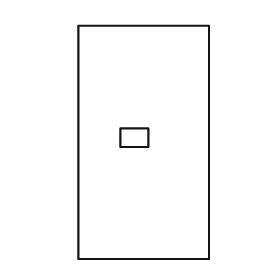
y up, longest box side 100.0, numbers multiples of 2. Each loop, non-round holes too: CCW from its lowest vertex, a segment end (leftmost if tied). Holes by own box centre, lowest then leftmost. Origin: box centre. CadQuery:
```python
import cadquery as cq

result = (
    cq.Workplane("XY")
    .moveTo(-28.0, -50.0)
    .lineTo(28.0, -50.0)
    .lineTo(28.0, 50.0)
    .lineTo(-28.0, 50.0)
    .close()
    .moveTo(-10.0, -2.0)
    .lineTo(2.0, -2.0)
    .lineTo(2.0, 6.0)
    .lineTo(-10.0, 6.0)
    .close()
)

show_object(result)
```